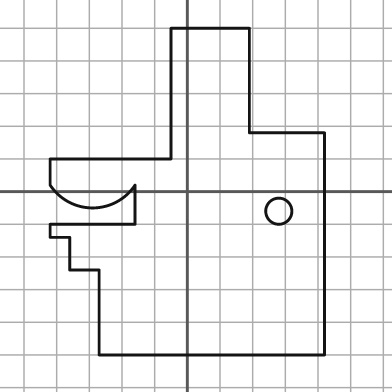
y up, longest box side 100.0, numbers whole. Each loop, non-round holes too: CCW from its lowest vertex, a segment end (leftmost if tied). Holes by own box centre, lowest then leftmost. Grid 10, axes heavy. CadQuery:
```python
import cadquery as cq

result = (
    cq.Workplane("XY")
    .moveTo(-27.0, -50.0)
    .lineTo(42.0, -50.0)
    .lineTo(42.0, 18.0)
    .lineTo(19.0, 18.0)
    .lineTo(19.0, 50.0)
    .lineTo(-5.0, 50.0)
    .lineTo(-5.0, 10.0)
    .lineTo(-42.0, 10.0)
    .lineTo(-42.0, 2.0)
    .threePointArc((-29.0, -5.0), (-16.0, 2.0))
    .lineTo(-16.0, -10.0)
    .lineTo(-42.0, -10.0)
    .lineTo(-42.0, -14.0)
    .lineTo(-36.0, -14.0)
    .lineTo(-36.0, -24.0)
    .lineTo(-27.0, -24.0)
    .close()
    .moveTo(28.0, -6.0)
    .circle(4.0)
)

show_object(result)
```